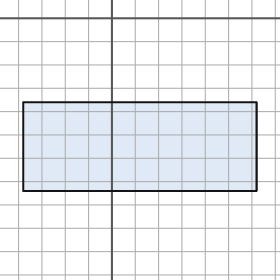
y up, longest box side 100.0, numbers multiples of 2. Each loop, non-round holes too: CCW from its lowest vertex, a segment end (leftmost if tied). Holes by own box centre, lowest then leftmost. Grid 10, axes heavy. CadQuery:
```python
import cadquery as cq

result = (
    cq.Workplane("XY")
    .moveTo(-38.0, -74.0)
    .lineTo(62.0, -74.0)
    .lineTo(62.0, -36.0)
    .lineTo(-38.0, -36.0)
    .close()
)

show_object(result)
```